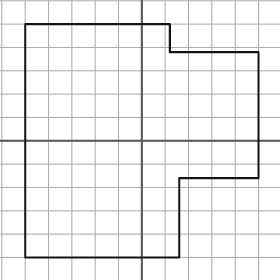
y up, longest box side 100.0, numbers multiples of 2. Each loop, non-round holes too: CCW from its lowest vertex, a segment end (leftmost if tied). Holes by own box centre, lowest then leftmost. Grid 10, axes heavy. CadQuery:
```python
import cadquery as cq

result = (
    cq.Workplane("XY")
    .moveTo(-50.0, -50.0)
    .lineTo(16.0, -50.0)
    .lineTo(16.0, -16.0)
    .lineTo(50.0, -16.0)
    .lineTo(50.0, 38.0)
    .lineTo(12.0, 38.0)
    .lineTo(12.0, 50.0)
    .lineTo(-50.0, 50.0)
    .close()
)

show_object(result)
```